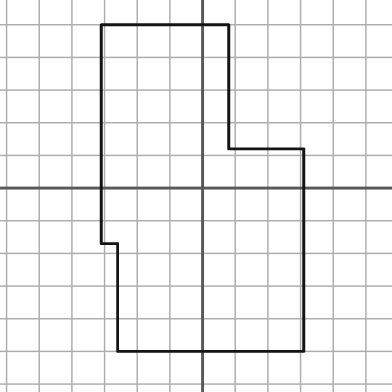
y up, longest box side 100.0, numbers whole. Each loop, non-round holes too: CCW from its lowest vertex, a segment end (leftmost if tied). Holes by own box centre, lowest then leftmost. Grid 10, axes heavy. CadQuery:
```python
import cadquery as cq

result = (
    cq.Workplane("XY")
    .moveTo(-26.0, -50.0)
    .lineTo(31.0, -50.0)
    .lineTo(31.0, 12.0)
    .lineTo(8.0, 12.0)
    .lineTo(8.0, 50.0)
    .lineTo(-31.0, 50.0)
    .lineTo(-31.0, -17.0)
    .lineTo(-26.0, -17.0)
    .close()
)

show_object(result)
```